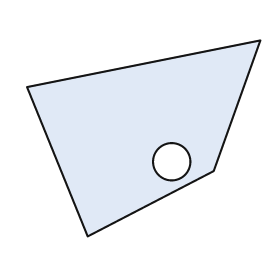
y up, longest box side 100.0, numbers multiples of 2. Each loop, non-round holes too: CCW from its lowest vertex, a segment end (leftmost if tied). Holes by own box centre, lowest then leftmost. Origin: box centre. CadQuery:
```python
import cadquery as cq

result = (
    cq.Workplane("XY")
    .moveTo(-24.0, -42.0)
    .lineTo(30.0, -14.0)
    .lineTo(50.0, 42.0)
    .lineTo(-50.0, 22.0)
    .close()
    .moveTo(12.0, -10.0)
    .circle(8.0)
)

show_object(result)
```